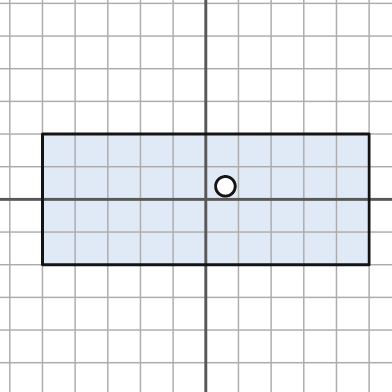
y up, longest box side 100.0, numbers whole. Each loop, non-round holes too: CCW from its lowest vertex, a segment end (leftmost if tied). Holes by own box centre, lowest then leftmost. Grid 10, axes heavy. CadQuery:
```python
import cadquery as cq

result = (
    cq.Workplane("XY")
    .moveTo(-50.0, -20.0)
    .lineTo(50.0, -20.0)
    .lineTo(50.0, 20.0)
    .lineTo(-50.0, 20.0)
    .close()
    .moveTo(6.0, 4.0)
    .circle(3.0)
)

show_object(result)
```